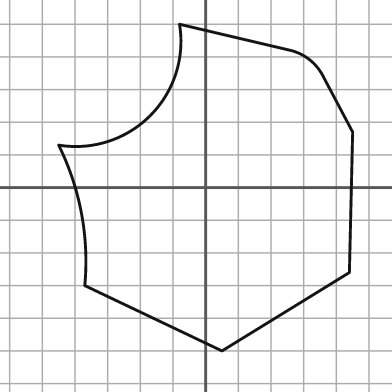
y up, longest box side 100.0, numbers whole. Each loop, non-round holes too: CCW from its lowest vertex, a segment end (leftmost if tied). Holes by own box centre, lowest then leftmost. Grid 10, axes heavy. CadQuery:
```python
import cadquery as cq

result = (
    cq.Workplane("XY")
    .moveTo(5.0, -50.0)
    .lineTo(44.0, -26.0)
    .lineTo(45.0, 17.0)
    .lineTo(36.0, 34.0)
    .threePointArc((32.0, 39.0), (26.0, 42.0))
    .lineTo(-8.0, 50.0)
    .threePointArc((-17.0, 22.0), (-45.0, 13.0))
    .threePointArc((-38.0, -8.0), (-37.0, -30.0))
    .close()
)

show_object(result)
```